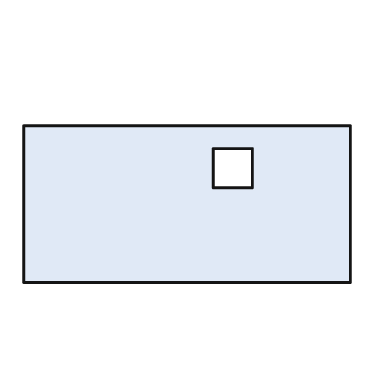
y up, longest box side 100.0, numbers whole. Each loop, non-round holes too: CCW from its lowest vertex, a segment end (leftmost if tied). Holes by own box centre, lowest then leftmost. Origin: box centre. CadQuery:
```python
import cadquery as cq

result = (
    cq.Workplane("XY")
    .moveTo(-50.0, -24.0)
    .lineTo(50.0, -24.0)
    .lineTo(50.0, 24.0)
    .lineTo(-50.0, 24.0)
    .close()
    .moveTo(8.0, 5.0)
    .lineTo(20.0, 5.0)
    .lineTo(20.0, 17.0)
    .lineTo(8.0, 17.0)
    .close()
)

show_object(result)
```